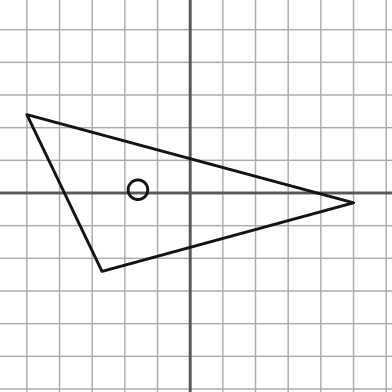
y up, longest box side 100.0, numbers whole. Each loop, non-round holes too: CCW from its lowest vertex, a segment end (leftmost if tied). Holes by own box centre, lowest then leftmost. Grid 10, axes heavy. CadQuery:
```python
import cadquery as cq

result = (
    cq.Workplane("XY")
    .moveTo(-27.0, -24.0)
    .lineTo(50.0, -3.0)
    .lineTo(-50.0, 24.0)
    .close()
    .moveTo(-16.0, 1.0)
    .circle(3.0)
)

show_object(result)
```